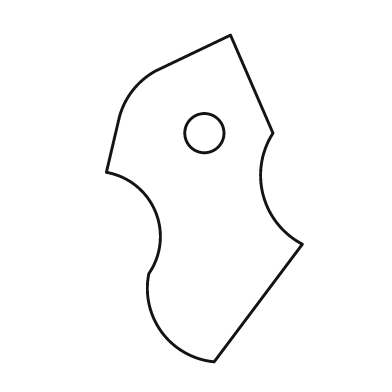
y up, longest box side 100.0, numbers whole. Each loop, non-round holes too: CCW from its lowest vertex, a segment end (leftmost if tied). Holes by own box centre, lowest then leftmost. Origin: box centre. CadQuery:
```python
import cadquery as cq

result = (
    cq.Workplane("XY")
    .moveTo(3.0, -50.0)
    .lineTo(30.0, -14.0)
    .threePointArc((18.0, 1.0), (21.0, 20.0))
    .lineTo(8.0, 50.0)
    .lineTo(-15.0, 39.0)
    .threePointArc((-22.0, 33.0), (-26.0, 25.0))
    .lineTo(-30.0, 8.0)
    .threePointArc((-15.0, -4.0), (-17.0, -23.0))
    .threePointArc((-13.0, -41.0), (3.0, -50.0))
    .close()
    .moveTo(0.0, 20.0)
    .circle(6.0)
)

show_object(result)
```